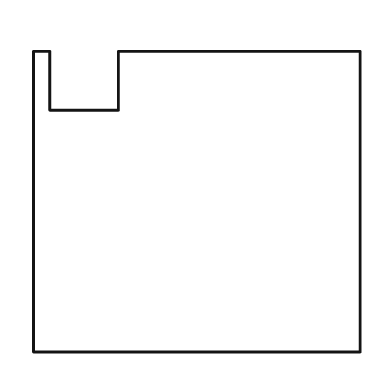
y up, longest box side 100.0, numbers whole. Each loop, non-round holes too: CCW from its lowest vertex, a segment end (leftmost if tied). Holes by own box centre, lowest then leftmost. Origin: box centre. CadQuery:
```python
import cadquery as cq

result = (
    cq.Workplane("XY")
    .moveTo(-50.0, -46.0)
    .lineTo(50.0, -46.0)
    .lineTo(50.0, 46.0)
    .lineTo(-24.0, 46.0)
    .lineTo(-24.0, 28.0)
    .lineTo(-45.0, 28.0)
    .lineTo(-45.0, 46.0)
    .lineTo(-50.0, 46.0)
    .close()
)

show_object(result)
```